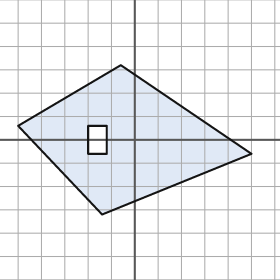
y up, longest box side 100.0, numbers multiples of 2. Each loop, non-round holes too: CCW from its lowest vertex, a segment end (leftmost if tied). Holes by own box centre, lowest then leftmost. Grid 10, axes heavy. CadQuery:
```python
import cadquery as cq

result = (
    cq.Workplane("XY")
    .moveTo(-14.0, -32.0)
    .lineTo(50.0, -6.0)
    .lineTo(-6.0, 32.0)
    .lineTo(-50.0, 6.0)
    .close()
    .moveTo(-20.0, -6.0)
    .lineTo(-12.0, -6.0)
    .lineTo(-12.0, 6.0)
    .lineTo(-20.0, 6.0)
    .close()
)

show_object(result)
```